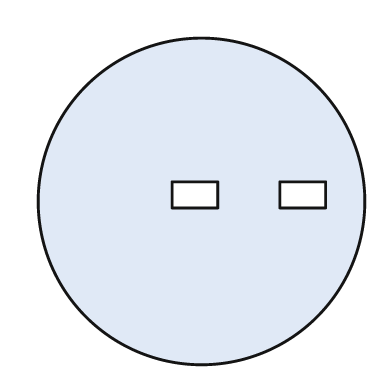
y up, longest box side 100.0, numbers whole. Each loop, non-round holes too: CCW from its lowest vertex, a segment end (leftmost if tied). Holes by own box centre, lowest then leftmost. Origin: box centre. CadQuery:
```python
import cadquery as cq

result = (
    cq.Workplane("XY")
    .moveTo(0.0, 0.0)
    .circle(50.0)
    .moveTo(-9.0, -2.0)
    .lineTo(5.0, -2.0)
    .lineTo(5.0, 6.0)
    .lineTo(-9.0, 6.0)
    .close()
    .moveTo(24.0, -2.0)
    .lineTo(38.0, -2.0)
    .lineTo(38.0, 6.0)
    .lineTo(24.0, 6.0)
    .close()
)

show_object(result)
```